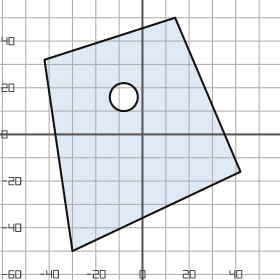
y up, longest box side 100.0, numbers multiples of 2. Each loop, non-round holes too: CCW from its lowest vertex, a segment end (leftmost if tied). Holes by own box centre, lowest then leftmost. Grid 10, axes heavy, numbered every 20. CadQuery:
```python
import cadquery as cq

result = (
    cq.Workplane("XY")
    .moveTo(-30.0, -50.0)
    .lineTo(42.0, -16.0)
    .lineTo(14.0, 50.0)
    .lineTo(-42.0, 32.0)
    .close()
    .moveTo(-8.0, 16.0)
    .circle(6.0)
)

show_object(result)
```